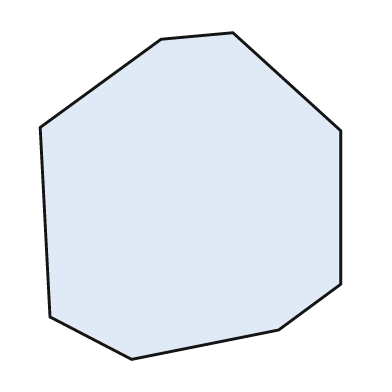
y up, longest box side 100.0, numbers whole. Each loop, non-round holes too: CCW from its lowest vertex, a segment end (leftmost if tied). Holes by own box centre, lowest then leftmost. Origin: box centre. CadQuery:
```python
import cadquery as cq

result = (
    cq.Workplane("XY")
    .moveTo(-18.0, -50.0)
    .lineTo(27.0, -41.0)
    .lineTo(46.0, -27.0)
    .lineTo(46.0, 20.0)
    .lineTo(13.0, 50.0)
    .lineTo(-9.0, 48.0)
    .lineTo(-46.0, 21.0)
    .lineTo(-43.0, -37.0)
    .close()
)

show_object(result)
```